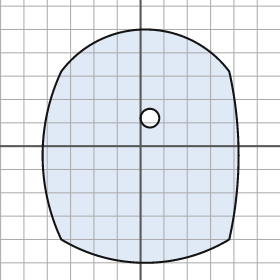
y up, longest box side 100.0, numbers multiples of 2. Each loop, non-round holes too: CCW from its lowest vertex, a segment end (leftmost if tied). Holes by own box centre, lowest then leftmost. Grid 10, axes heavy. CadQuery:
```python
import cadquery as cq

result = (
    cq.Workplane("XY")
    .moveTo(-34.0, -40.0)
    .threePointArc((2.0, -50.0), (38.0, -40.0))
    .threePointArc((42.0, -4.0), (38.0, 32.0))
    .threePointArc((2.0, 50.0), (-34.0, 32.0))
    .threePointArc((-42.0, -4.0), (-34.0, -40.0))
    .close()
    .moveTo(4.0, 12.0)
    .circle(4.0)
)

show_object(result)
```